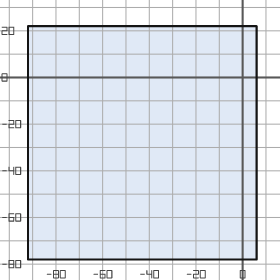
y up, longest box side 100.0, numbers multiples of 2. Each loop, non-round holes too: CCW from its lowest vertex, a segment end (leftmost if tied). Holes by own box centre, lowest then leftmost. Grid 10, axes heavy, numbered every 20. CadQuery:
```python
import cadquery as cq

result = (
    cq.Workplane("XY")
    .moveTo(-92.0, -78.0)
    .lineTo(6.0, -78.0)
    .lineTo(6.0, 22.0)
    .lineTo(-92.0, 22.0)
    .close()
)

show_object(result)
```